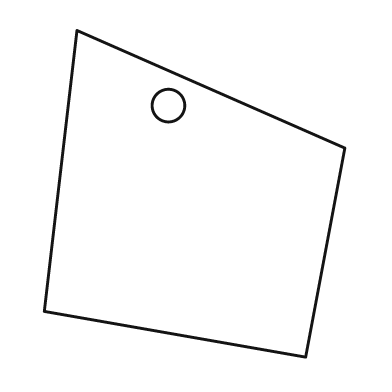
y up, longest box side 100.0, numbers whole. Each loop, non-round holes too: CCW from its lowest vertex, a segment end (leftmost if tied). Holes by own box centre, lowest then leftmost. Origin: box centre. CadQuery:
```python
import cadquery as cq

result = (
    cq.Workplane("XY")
    .moveTo(34.0, -50.0)
    .lineTo(46.0, 14.0)
    .lineTo(-36.0, 50.0)
    .lineTo(-46.0, -36.0)
    .close()
    .moveTo(-8.0, 27.0)
    .circle(5.0)
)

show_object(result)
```